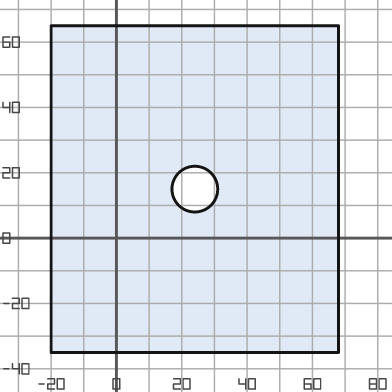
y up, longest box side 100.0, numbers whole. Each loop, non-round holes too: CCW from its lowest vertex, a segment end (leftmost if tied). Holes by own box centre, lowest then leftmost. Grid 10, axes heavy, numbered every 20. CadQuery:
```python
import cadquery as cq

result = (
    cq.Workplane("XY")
    .moveTo(-20.0, -35.0)
    .lineTo(68.0, -35.0)
    .lineTo(68.0, 65.0)
    .lineTo(-20.0, 65.0)
    .close()
    .moveTo(24.0, 15.0)
    .circle(7.0)
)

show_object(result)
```